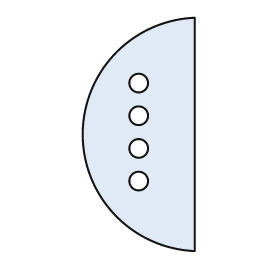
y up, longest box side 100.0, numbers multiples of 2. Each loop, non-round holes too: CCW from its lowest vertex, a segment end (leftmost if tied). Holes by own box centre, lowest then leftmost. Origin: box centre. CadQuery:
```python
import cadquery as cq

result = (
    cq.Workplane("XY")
    .moveTo(24.0, -50.0)
    .lineTo(24.0, 50.0)
    .threePointArc((-24.0, 0.0), (24.0, -50.0))
    .close()
    .moveTo(0.0, -20.0)
    .circle(4.0)
    .moveTo(0.0, -6.0)
    .circle(4.0)
    .moveTo(0.0, 8.0)
    .circle(4.0)
    .moveTo(0.0, 22.0)
    .circle(4.0)
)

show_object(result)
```